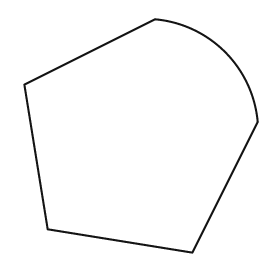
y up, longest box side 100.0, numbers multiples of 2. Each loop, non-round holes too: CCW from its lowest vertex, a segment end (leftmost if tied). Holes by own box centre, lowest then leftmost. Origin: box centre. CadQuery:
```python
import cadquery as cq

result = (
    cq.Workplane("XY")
    .moveTo(22.0, -50.0)
    .lineTo(50.0, 6.0)
    .threePointArc((36.0, 36.0), (6.0, 50.0))
    .lineTo(-50.0, 22.0)
    .lineTo(-40.0, -40.0)
    .close()
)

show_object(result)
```